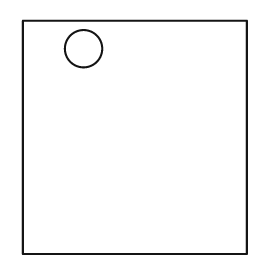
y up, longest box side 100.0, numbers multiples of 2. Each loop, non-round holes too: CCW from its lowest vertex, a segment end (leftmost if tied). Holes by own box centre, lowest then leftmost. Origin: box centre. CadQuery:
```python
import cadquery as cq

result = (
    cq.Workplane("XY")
    .moveTo(-48.0, -50.0)
    .lineTo(48.0, -50.0)
    .lineTo(48.0, 50.0)
    .lineTo(-48.0, 50.0)
    .close()
    .moveTo(-22.0, 38.0)
    .circle(8.0)
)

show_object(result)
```